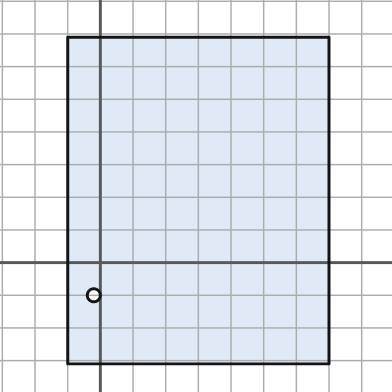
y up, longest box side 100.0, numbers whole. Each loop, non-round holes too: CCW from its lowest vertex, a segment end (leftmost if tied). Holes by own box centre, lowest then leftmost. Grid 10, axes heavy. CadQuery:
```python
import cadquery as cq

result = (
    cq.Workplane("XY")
    .moveTo(-10.0, -31.0)
    .lineTo(70.0, -31.0)
    .lineTo(70.0, 69.0)
    .lineTo(-10.0, 69.0)
    .close()
    .moveTo(-2.0, -10.0)
    .circle(2.0)
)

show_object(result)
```